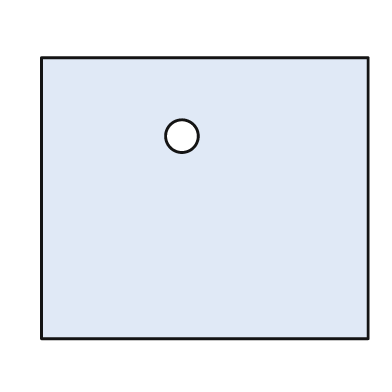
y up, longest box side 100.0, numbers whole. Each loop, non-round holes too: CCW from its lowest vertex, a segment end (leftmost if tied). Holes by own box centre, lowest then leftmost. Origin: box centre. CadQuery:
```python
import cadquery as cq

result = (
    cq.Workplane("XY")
    .moveTo(-50.0, -43.0)
    .lineTo(50.0, -43.0)
    .lineTo(50.0, 43.0)
    .lineTo(-50.0, 43.0)
    .close()
    .moveTo(-7.0, 19.0)
    .circle(5.0)
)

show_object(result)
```